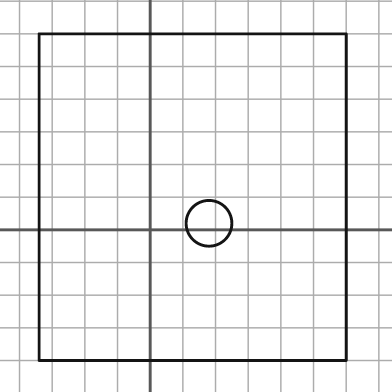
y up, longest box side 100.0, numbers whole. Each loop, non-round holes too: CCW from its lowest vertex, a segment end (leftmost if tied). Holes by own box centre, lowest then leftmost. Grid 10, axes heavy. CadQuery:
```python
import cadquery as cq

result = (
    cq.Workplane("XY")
    .moveTo(-34.0, -40.0)
    .lineTo(60.0, -40.0)
    .lineTo(60.0, 60.0)
    .lineTo(-34.0, 60.0)
    .close()
    .moveTo(18.0, 2.0)
    .circle(7.0)
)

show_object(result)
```